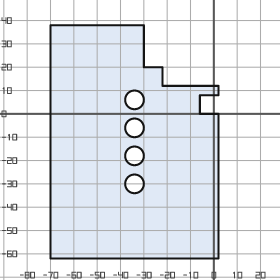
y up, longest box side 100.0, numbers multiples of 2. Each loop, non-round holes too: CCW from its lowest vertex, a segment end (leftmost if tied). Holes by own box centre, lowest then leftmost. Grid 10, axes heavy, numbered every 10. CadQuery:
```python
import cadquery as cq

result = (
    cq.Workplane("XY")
    .moveTo(-70.0, -62.0)
    .lineTo(2.0, -62.0)
    .lineTo(2.0, 0.0)
    .lineTo(-6.0, 0.0)
    .lineTo(-6.0, 8.0)
    .lineTo(2.0, 8.0)
    .lineTo(2.0, 12.0)
    .lineTo(-22.0, 12.0)
    .lineTo(-22.0, 20.0)
    .lineTo(-30.0, 20.0)
    .lineTo(-30.0, 38.0)
    .lineTo(-70.0, 38.0)
    .close()
    .moveTo(-34.0, -30.0)
    .circle(4.0)
    .moveTo(-34.0, -18.0)
    .circle(4.0)
    .moveTo(-34.0, -6.0)
    .circle(4.0)
    .moveTo(-34.0, 6.0)
    .circle(4.0)
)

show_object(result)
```